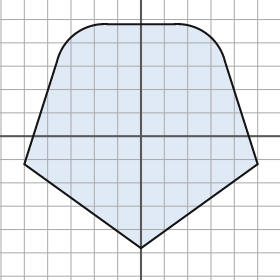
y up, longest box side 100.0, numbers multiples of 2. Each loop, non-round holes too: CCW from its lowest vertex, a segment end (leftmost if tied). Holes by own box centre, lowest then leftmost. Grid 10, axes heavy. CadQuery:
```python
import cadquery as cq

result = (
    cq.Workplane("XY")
    .moveTo(0.0, -48.0)
    .lineTo(50.0, -12.0)
    .lineTo(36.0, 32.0)
    .threePointArc((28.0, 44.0), (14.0, 48.0))
    .lineTo(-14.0, 48.0)
    .threePointArc((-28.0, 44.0), (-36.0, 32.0))
    .lineTo(-50.0, -12.0)
    .close()
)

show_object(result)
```